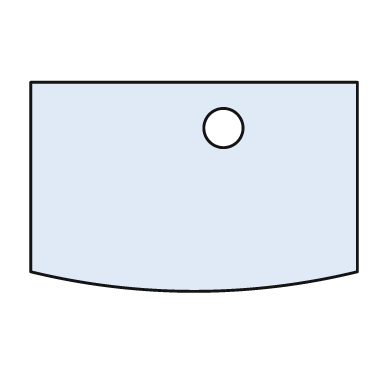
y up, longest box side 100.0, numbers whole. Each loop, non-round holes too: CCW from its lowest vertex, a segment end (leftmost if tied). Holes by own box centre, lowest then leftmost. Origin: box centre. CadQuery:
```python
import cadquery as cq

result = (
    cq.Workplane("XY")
    .moveTo(-50.0, -26.0)
    .threePointArc((0.0, -32.0), (50.0, -26.0))
    .lineTo(50.0, 32.0)
    .lineTo(-50.0, 32.0)
    .close()
    .moveTo(9.0, 18.0)
    .circle(6.0)
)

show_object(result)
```